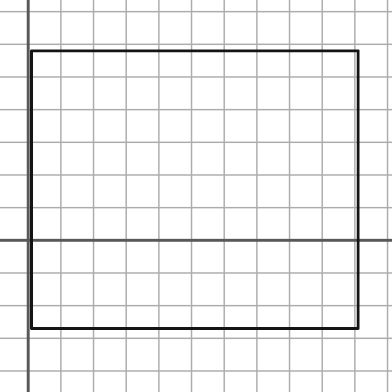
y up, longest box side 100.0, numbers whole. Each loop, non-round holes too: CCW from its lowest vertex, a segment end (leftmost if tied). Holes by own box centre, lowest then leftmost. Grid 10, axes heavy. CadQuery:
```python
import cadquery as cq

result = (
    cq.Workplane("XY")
    .moveTo(1.0, -27.0)
    .lineTo(101.0, -27.0)
    .lineTo(101.0, 58.0)
    .lineTo(1.0, 58.0)
    .close()
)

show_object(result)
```